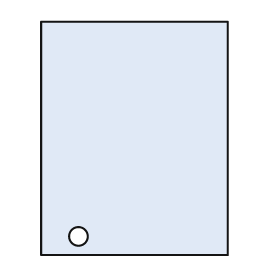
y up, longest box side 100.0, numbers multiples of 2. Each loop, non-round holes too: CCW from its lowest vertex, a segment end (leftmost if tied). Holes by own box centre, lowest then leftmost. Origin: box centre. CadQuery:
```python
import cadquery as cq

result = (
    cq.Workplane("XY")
    .moveTo(-40.0, -50.0)
    .lineTo(40.0, -50.0)
    .lineTo(40.0, 50.0)
    .lineTo(-40.0, 50.0)
    .close()
    .moveTo(-24.0, -42.0)
    .circle(4.0)
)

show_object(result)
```